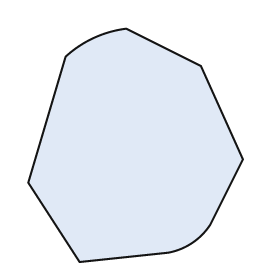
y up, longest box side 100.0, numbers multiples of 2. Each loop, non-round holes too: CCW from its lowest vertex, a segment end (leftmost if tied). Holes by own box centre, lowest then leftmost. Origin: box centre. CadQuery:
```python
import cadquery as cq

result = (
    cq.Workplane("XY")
    .moveTo(-24.0, -50.0)
    .lineTo(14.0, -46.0)
    .threePointArc((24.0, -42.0), (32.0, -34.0))
    .lineTo(46.0, -6.0)
    .lineTo(28.0, 34.0)
    .lineTo(-4.0, 50.0)
    .threePointArc((-18.0, 46.0), (-30.0, 38.0))
    .lineTo(-46.0, -16.0)
    .close()
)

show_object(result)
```